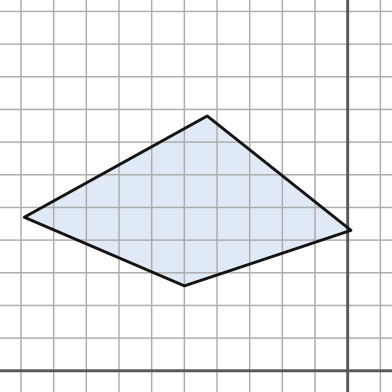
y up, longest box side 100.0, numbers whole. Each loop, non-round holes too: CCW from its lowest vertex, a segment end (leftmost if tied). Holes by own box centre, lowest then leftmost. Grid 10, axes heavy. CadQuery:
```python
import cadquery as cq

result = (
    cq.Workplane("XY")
    .moveTo(-50.0, 26.0)
    .lineTo(1.0, 43.0)
    .lineTo(-43.0, 78.0)
    .lineTo(-99.0, 47.0)
    .close()
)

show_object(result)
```